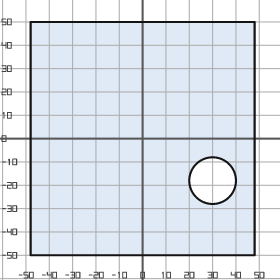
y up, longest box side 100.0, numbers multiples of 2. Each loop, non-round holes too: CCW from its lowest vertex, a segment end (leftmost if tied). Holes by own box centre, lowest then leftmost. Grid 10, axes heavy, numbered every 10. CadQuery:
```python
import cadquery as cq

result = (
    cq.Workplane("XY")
    .moveTo(-48.0, -50.0)
    .lineTo(48.0, -50.0)
    .lineTo(48.0, 50.0)
    .lineTo(-48.0, 50.0)
    .close()
    .moveTo(30.0, -18.0)
    .circle(10.0)
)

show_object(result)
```